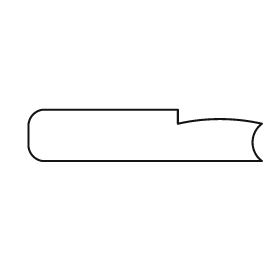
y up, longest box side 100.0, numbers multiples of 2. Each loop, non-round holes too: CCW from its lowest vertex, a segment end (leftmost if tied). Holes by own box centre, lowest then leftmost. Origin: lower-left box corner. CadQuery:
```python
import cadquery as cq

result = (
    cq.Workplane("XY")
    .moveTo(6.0, 0.0)
    .lineTo(100.0, 0.0)
    .threePointArc((96.0, 8.0), (100.0, 16.0))
    .threePointArc((82.0, 18.0), (64.0, 16.0))
    .lineTo(64.0, 22.0)
    .lineTo(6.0, 22.0)
    .threePointArc((2.0, 20.0), (0.0, 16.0))
    .lineTo(0.0, 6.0)
    .threePointArc((2.0, 2.0), (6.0, 0.0))
    .close()
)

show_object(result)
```